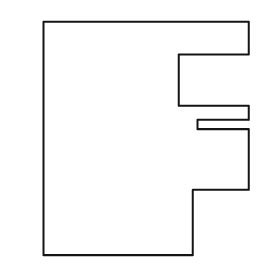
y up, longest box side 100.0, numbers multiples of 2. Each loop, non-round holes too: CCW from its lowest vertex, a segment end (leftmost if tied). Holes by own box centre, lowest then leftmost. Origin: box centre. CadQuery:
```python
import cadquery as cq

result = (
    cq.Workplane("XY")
    .moveTo(-44.0, -50.0)
    .lineTo(20.0, -50.0)
    .lineTo(20.0, -22.0)
    .lineTo(44.0, -22.0)
    .lineTo(44.0, 4.0)
    .lineTo(22.0, 4.0)
    .lineTo(22.0, 8.0)
    .lineTo(44.0, 8.0)
    .lineTo(44.0, 14.0)
    .lineTo(14.0, 14.0)
    .lineTo(14.0, 36.0)
    .lineTo(44.0, 36.0)
    .lineTo(44.0, 50.0)
    .lineTo(-44.0, 50.0)
    .close()
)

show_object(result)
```